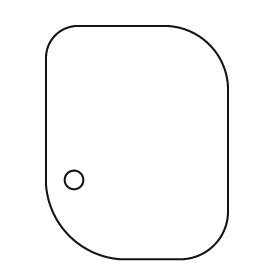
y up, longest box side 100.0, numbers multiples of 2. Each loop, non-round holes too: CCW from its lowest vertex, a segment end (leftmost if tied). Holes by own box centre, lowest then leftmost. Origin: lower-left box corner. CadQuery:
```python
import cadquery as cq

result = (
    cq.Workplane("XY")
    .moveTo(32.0, 0.0)
    .lineTo(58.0, 0.0)
    .threePointArc((72.0, 6.0), (78.0, 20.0))
    .lineTo(78.0, 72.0)
    .threePointArc((70.0, 92.0), (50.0, 100.0))
    .lineTo(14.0, 100.0)
    .threePointArc((4.0, 96.0), (0.0, 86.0))
    .lineTo(0.0, 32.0)
    .threePointArc((10.0, 10.0), (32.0, 0.0))
    .close()
    .moveTo(12.0, 34.0)
    .circle(4.0)
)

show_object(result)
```